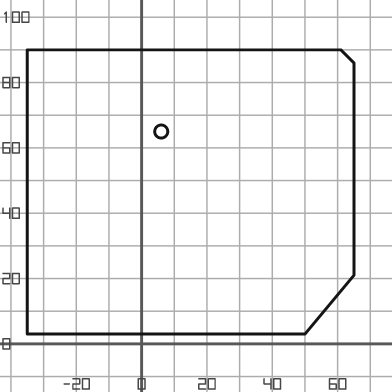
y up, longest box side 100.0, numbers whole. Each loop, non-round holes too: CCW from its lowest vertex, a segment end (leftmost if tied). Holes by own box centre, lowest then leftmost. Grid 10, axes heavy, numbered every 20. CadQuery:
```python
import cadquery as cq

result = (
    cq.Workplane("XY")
    .moveTo(-35.0, 3.0)
    .lineTo(50.0, 3.0)
    .lineTo(65.0, 21.0)
    .lineTo(65.0, 86.0)
    .lineTo(61.0, 90.0)
    .lineTo(-35.0, 90.0)
    .close()
    .moveTo(6.0, 65.0)
    .circle(2.0)
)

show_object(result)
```